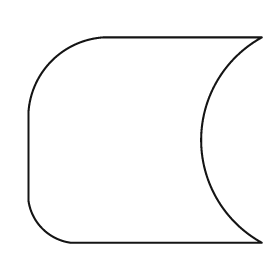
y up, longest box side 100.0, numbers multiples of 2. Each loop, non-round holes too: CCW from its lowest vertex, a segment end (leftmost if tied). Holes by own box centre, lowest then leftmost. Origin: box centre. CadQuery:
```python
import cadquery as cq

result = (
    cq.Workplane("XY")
    .moveTo(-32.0, -44.0)
    .lineTo(50.0, -44.0)
    .threePointArc((24.0, 0.0), (50.0, 44.0))
    .lineTo(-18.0, 44.0)
    .threePointArc((-40.0, 34.0), (-50.0, 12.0))
    .lineTo(-50.0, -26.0)
    .threePointArc((-44.0, -38.0), (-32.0, -44.0))
    .close()
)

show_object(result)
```